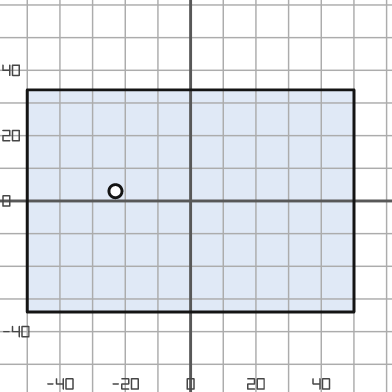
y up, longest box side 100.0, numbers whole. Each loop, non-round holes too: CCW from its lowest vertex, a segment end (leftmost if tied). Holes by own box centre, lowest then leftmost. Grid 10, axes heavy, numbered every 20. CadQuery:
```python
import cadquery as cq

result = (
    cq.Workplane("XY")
    .moveTo(-50.0, -34.0)
    .lineTo(50.0, -34.0)
    .lineTo(50.0, 34.0)
    .lineTo(-50.0, 34.0)
    .close()
    .moveTo(-23.0, 3.0)
    .circle(2.0)
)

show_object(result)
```